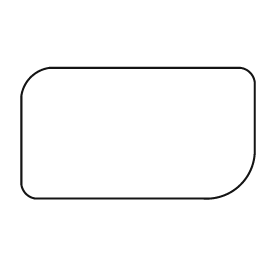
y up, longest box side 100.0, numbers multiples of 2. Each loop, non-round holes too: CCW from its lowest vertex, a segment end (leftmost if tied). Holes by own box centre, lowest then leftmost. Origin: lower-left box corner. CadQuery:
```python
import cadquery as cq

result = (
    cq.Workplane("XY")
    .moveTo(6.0, 0.0)
    .lineTo(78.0, 0.0)
    .threePointArc((94.0, 6.0), (100.0, 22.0))
    .lineTo(100.0, 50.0)
    .threePointArc((98.0, 54.0), (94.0, 56.0))
    .lineTo(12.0, 56.0)
    .threePointArc((4.0, 52.0), (0.0, 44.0))
    .lineTo(0.0, 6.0)
    .threePointArc((2.0, 2.0), (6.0, 0.0))
    .close()
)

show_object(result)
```